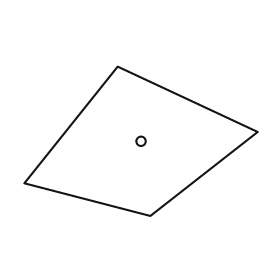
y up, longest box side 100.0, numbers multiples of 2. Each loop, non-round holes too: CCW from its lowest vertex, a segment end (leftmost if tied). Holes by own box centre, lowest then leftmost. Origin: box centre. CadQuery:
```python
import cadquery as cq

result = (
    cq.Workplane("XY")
    .moveTo(4.0, -32.0)
    .lineTo(50.0, 4.0)
    .lineTo(-10.0, 32.0)
    .lineTo(-50.0, -18.0)
    .close()
    .moveTo(0.0, 0.0)
    .circle(2.0)
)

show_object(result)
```